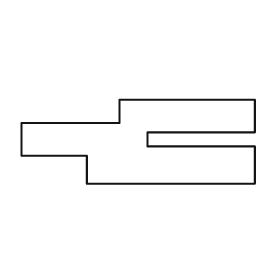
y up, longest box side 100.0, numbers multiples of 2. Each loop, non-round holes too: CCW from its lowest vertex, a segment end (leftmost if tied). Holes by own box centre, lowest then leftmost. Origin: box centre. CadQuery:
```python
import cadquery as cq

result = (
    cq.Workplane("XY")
    .moveTo(-22.0, -18.0)
    .lineTo(50.0, -18.0)
    .lineTo(50.0, -2.0)
    .lineTo(4.0, -2.0)
    .lineTo(4.0, 4.0)
    .lineTo(50.0, 4.0)
    .lineTo(50.0, 18.0)
    .lineTo(-8.0, 18.0)
    .lineTo(-8.0, 8.0)
    .lineTo(-50.0, 8.0)
    .lineTo(-50.0, -6.0)
    .lineTo(-22.0, -6.0)
    .close()
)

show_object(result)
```